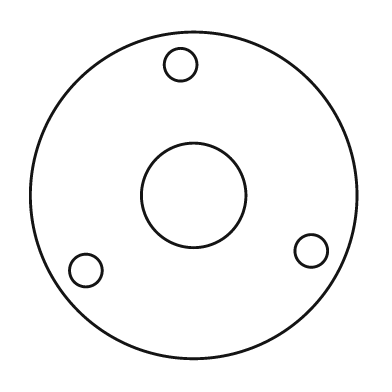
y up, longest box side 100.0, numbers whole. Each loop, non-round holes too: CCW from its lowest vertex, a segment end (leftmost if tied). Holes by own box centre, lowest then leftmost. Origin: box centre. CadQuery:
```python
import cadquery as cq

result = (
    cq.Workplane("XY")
    .moveTo(0.0, 0.0)
    .circle(50.0)
    .moveTo(-33.0, -23.0)
    .circle(5.0)
    .moveTo(36.0, -17.0)
    .circle(5.0)
    .moveTo(0.0, 0.0)
    .circle(16.0)
    .moveTo(-4.0, 40.0)
    .circle(5.0)
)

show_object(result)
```